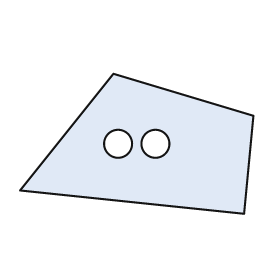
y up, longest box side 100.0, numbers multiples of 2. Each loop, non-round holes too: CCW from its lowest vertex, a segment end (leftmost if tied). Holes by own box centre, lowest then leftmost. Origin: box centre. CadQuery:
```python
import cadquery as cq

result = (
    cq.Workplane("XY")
    .moveTo(46.0, -30.0)
    .lineTo(50.0, 12.0)
    .lineTo(-10.0, 30.0)
    .lineTo(-50.0, -20.0)
    .close()
    .moveTo(-8.0, 0.0)
    .circle(6.0)
    .moveTo(8.0, 0.0)
    .circle(6.0)
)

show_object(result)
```